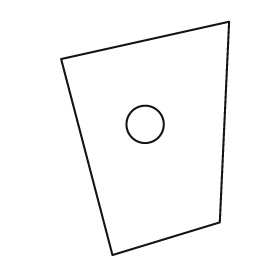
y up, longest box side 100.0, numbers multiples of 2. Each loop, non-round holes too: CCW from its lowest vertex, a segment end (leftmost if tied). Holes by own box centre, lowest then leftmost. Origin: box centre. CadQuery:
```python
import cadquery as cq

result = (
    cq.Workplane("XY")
    .moveTo(-14.0, -50.0)
    .lineTo(32.0, -36.0)
    .lineTo(36.0, 50.0)
    .lineTo(-36.0, 34.0)
    .close()
    .moveTo(0.0, 6.0)
    .circle(8.0)
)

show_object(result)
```